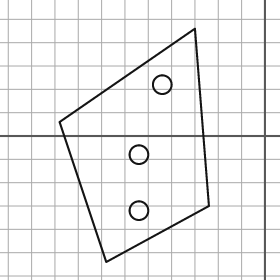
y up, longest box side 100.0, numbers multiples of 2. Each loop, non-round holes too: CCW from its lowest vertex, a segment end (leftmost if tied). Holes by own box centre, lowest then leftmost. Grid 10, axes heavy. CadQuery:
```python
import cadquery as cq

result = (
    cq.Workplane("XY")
    .moveTo(-68.0, -54.0)
    .lineTo(-24.0, -30.0)
    .lineTo(-30.0, 46.0)
    .lineTo(-88.0, 6.0)
    .close()
    .moveTo(-54.0, -32.0)
    .circle(4.0)
    .moveTo(-54.0, -8.0)
    .circle(4.0)
    .moveTo(-44.0, 22.0)
    .circle(4.0)
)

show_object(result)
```